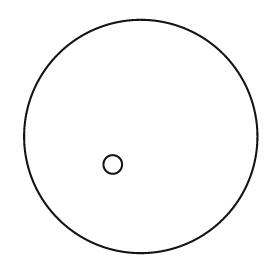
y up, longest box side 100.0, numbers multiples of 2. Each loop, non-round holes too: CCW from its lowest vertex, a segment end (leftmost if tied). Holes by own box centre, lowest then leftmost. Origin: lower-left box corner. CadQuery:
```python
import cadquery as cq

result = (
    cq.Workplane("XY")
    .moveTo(50.0, 50.0)
    .circle(50.0)
    .moveTo(38.0, 38.0)
    .circle(4.0)
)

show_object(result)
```